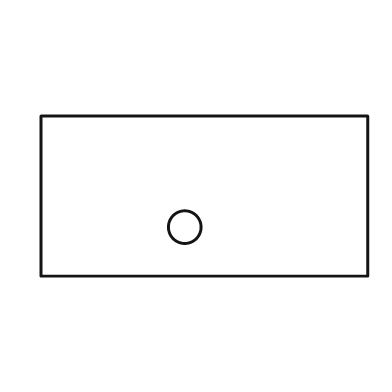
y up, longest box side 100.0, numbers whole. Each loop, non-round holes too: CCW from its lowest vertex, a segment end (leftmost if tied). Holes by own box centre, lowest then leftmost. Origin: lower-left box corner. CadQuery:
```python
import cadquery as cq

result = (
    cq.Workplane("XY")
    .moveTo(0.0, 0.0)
    .lineTo(100.0, 0.0)
    .lineTo(100.0, 49.0)
    .lineTo(0.0, 49.0)
    .close()
    .moveTo(44.0, 15.0)
    .circle(5.0)
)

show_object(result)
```